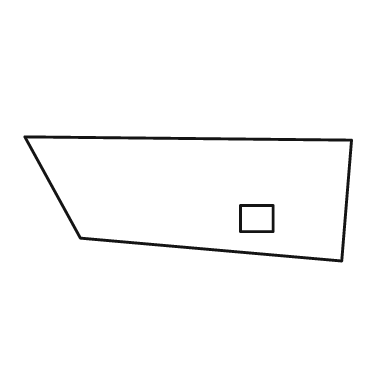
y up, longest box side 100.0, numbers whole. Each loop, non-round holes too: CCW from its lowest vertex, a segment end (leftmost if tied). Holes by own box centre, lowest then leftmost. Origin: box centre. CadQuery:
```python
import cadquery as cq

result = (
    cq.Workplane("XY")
    .moveTo(47.0, -19.0)
    .lineTo(50.0, 18.0)
    .lineTo(-50.0, 19.0)
    .lineTo(-33.0, -12.0)
    .close()
    .moveTo(16.0, -10.0)
    .lineTo(26.0, -10.0)
    .lineTo(26.0, -2.0)
    .lineTo(16.0, -2.0)
    .close()
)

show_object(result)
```